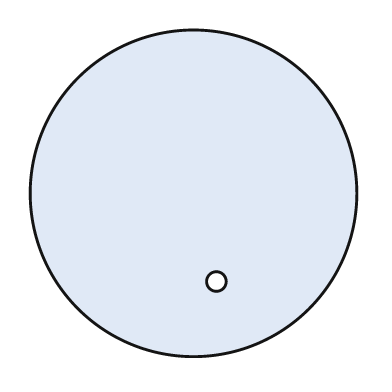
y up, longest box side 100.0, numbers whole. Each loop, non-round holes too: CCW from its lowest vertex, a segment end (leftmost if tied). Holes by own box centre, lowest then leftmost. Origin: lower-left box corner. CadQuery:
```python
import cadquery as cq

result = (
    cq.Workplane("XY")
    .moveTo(50.0, 50.0)
    .circle(50.0)
    .moveTo(57.0, 23.0)
    .circle(3.0)
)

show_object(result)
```